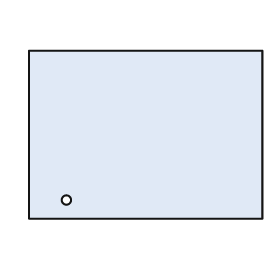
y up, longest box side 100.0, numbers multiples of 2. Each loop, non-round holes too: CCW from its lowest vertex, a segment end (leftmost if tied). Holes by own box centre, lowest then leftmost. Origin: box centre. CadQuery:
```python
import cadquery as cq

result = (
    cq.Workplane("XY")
    .moveTo(-50.0, -36.0)
    .lineTo(50.0, -36.0)
    .lineTo(50.0, 36.0)
    .lineTo(-50.0, 36.0)
    .close()
    .moveTo(-34.0, -28.0)
    .circle(2.0)
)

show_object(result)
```